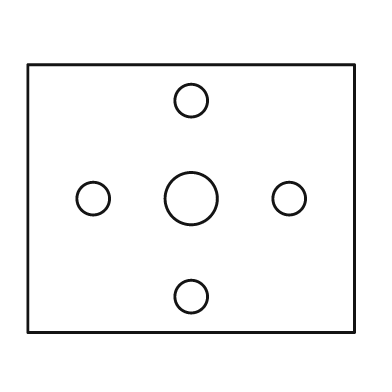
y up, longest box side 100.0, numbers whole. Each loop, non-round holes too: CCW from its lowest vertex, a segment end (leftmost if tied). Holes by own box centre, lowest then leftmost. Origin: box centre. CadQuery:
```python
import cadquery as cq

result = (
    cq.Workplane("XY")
    .moveTo(-50.0, -41.0)
    .lineTo(50.0, -41.0)
    .lineTo(50.0, 41.0)
    .lineTo(-50.0, 41.0)
    .close()
    .moveTo(0.0, -30.0)
    .circle(5.0)
    .moveTo(-30.0, 0.0)
    .circle(5.0)
    .moveTo(0.0, 0.0)
    .circle(8.0)
    .moveTo(30.0, 0.0)
    .circle(5.0)
    .moveTo(0.0, 30.0)
    .circle(5.0)
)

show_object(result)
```